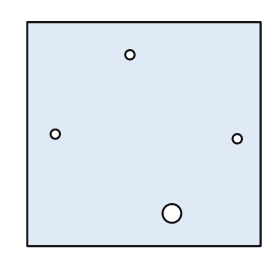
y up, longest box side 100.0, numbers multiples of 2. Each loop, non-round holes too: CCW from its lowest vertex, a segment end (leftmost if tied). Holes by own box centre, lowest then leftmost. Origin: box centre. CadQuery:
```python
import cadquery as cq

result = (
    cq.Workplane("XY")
    .moveTo(-50.0, -48.0)
    .lineTo(50.0, -48.0)
    .lineTo(50.0, 48.0)
    .lineTo(-50.0, 48.0)
    .close()
    .moveTo(12.0, -34.0)
    .circle(4.0)
    .moveTo(40.0, -2.0)
    .circle(2.0)
    .moveTo(-38.0, 0.0)
    .circle(2.0)
    .moveTo(-6.0, 34.0)
    .circle(2.0)
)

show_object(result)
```